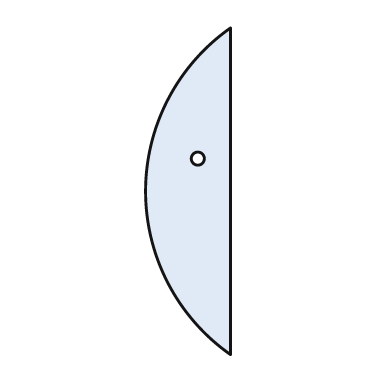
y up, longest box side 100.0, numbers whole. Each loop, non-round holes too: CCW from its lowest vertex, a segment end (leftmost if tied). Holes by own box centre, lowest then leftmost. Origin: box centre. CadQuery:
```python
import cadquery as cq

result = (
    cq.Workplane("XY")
    .moveTo(13.0, -50.0)
    .lineTo(13.0, 50.0)
    .threePointArc((-13.0, 0.0), (13.0, -50.0))
    .close()
    .moveTo(3.0, 10.0)
    .circle(2.0)
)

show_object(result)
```